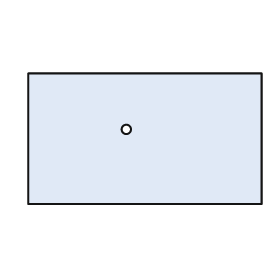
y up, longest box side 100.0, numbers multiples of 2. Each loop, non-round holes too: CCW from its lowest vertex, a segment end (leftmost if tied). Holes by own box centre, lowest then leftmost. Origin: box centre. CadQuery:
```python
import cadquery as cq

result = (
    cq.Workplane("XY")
    .moveTo(-50.0, -28.0)
    .lineTo(50.0, -28.0)
    .lineTo(50.0, 28.0)
    .lineTo(-50.0, 28.0)
    .close()
    .moveTo(-8.0, 4.0)
    .circle(2.0)
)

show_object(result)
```